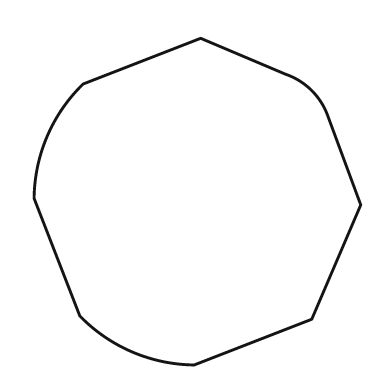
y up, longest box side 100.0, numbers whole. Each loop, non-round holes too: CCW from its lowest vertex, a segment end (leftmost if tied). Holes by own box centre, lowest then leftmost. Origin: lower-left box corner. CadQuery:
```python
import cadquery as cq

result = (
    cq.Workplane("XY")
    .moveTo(49.0, 0.0)
    .lineTo(85.0, 14.0)
    .lineTo(100.0, 49.0)
    .lineTo(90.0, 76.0)
    .threePointArc((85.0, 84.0), (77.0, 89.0))
    .lineTo(51.0, 100.0)
    .lineTo(15.0, 86.0)
    .threePointArc((4.0, 70.0), (0.0, 51.0))
    .lineTo(14.0, 15.0)
    .threePointArc((30.0, 4.0), (49.0, 0.0))
    .close()
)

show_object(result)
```